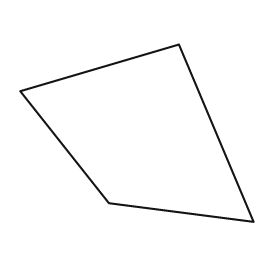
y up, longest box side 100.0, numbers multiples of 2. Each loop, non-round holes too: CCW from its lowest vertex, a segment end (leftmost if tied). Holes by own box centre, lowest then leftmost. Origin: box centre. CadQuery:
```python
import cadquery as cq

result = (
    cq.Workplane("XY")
    .moveTo(50.0, -38.0)
    .lineTo(18.0, 38.0)
    .lineTo(-50.0, 18.0)
    .lineTo(-12.0, -30.0)
    .close()
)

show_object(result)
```